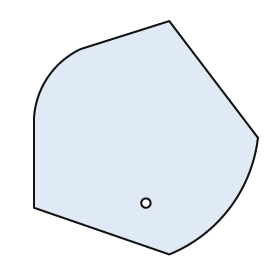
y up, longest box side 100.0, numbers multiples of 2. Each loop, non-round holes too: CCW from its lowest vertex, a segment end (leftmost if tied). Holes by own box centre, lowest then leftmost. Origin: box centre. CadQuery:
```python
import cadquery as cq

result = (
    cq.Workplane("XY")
    .moveTo(10.0, -50.0)
    .threePointArc((36.0, -30.0), (48.0, 0.0))
    .lineTo(10.0, 50.0)
    .lineTo(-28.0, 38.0)
    .threePointArc((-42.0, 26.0), (-48.0, 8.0))
    .lineTo(-48.0, -30.0)
    .close()
    .moveTo(0.0, -28.0)
    .circle(2.0)
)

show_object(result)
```